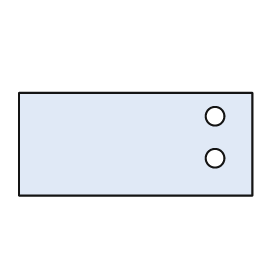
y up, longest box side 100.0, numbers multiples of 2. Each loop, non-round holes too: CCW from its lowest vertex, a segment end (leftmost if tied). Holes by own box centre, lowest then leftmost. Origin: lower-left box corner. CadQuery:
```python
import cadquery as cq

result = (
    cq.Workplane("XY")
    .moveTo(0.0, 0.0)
    .lineTo(100.0, 0.0)
    .lineTo(100.0, 44.0)
    .lineTo(0.0, 44.0)
    .close()
    .moveTo(84.0, 16.0)
    .circle(4.0)
    .moveTo(84.0, 34.0)
    .circle(4.0)
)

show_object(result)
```